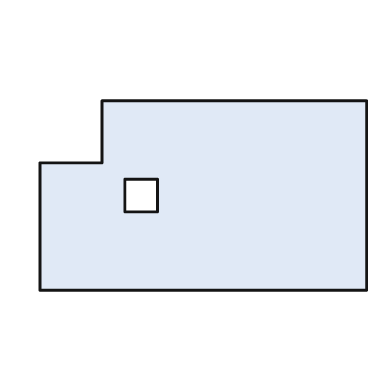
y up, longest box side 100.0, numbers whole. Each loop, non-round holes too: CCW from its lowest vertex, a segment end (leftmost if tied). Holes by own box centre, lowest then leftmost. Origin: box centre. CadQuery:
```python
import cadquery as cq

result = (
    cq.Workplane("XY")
    .moveTo(-50.0, -29.0)
    .lineTo(50.0, -29.0)
    .lineTo(50.0, 29.0)
    .lineTo(-31.0, 29.0)
    .lineTo(-31.0, 10.0)
    .lineTo(-50.0, 10.0)
    .close()
    .moveTo(-24.0, -5.0)
    .lineTo(-14.0, -5.0)
    .lineTo(-14.0, 5.0)
    .lineTo(-24.0, 5.0)
    .close()
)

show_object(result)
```